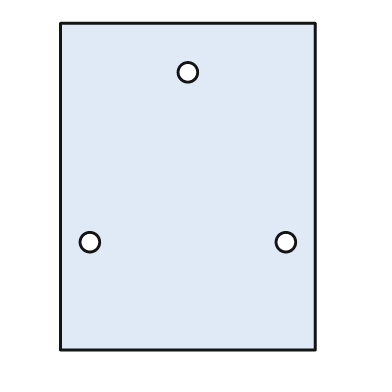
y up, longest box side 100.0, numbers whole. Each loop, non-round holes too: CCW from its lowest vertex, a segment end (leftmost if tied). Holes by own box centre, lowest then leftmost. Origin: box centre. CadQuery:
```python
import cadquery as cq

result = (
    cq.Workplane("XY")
    .moveTo(-39.0, -50.0)
    .lineTo(39.0, -50.0)
    .lineTo(39.0, 50.0)
    .lineTo(-39.0, 50.0)
    .close()
    .moveTo(-30.0, -17.0)
    .circle(3.0)
    .moveTo(30.0, -17.0)
    .circle(3.0)
    .moveTo(0.0, 35.0)
    .circle(3.0)
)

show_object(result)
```